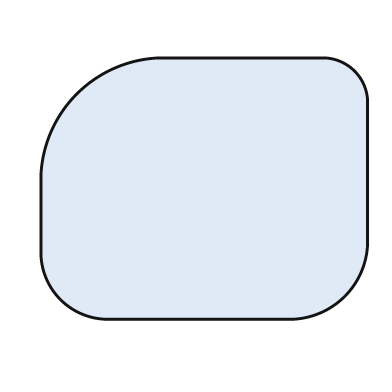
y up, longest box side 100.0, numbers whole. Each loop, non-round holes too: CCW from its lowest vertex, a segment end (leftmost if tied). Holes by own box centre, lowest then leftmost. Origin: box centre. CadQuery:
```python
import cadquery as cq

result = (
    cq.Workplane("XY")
    .moveTo(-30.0, -40.0)
    .lineTo(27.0, -40.0)
    .threePointArc((43.0, -33.0), (50.0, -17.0))
    .lineTo(50.0, 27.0)
    .threePointArc((46.0, 36.0), (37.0, 40.0))
    .lineTo(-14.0, 40.0)
    .threePointArc((-39.0, 29.0), (-50.0, 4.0))
    .lineTo(-50.0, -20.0)
    .threePointArc((-44.0, -34.0), (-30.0, -40.0))
    .close()
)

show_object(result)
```